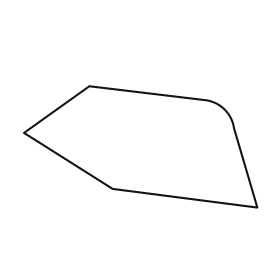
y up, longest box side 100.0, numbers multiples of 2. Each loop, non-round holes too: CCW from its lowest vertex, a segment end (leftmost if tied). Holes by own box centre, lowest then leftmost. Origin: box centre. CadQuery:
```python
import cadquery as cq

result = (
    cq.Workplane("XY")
    .moveTo(50.0, -26.0)
    .lineTo(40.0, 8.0)
    .threePointArc((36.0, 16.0), (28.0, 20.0))
    .lineTo(-22.0, 26.0)
    .lineTo(-50.0, 6.0)
    .lineTo(-12.0, -18.0)
    .close()
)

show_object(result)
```